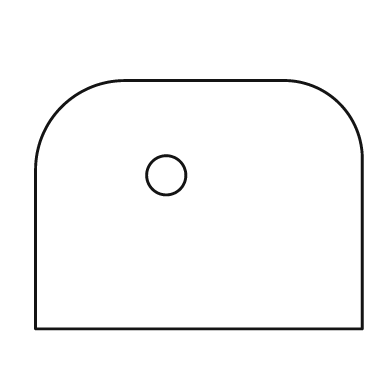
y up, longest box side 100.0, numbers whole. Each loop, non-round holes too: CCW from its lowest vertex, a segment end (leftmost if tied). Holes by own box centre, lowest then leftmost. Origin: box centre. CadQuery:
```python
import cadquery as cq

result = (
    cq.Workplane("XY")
    .moveTo(-50.0, -38.0)
    .lineTo(50.0, -38.0)
    .lineTo(50.0, 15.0)
    .threePointArc((43.0, 31.0), (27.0, 38.0))
    .lineTo(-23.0, 38.0)
    .threePointArc((-42.0, 30.0), (-50.0, 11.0))
    .close()
    .moveTo(-10.0, 9.0)
    .circle(6.0)
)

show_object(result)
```